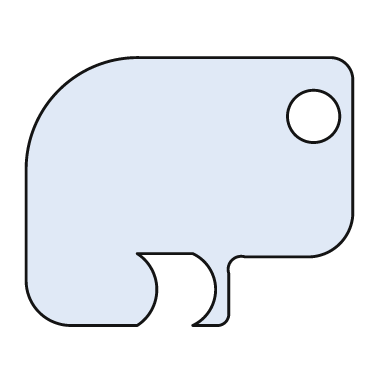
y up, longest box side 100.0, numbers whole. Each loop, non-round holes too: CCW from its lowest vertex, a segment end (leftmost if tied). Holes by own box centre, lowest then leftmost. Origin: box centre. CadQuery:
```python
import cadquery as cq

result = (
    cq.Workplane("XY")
    .moveTo(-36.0, -41.0)
    .lineTo(-16.0, -41.0)
    .threePointArc((-10.0, -30.0), (-16.0, -19.0))
    .lineTo(1.0, -19.0)
    .threePointArc((8.0, -30.0), (1.0, -41.0))
    .lineTo(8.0, -41.0)
    .threePointArc((11.0, -40.0), (12.0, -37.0))
    .lineTo(12.0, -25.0)
    .threePointArc((13.0, -21.0), (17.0, -20.0))
    .lineTo(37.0, -20.0)
    .threePointArc((46.0, -16.0), (50.0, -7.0))
    .lineTo(50.0, 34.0)
    .threePointArc((48.0, 39.0), (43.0, 41.0))
    .lineTo(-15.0, 41.0)
    .threePointArc((-40.0, 31.0), (-50.0, 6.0))
    .lineTo(-50.0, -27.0)
    .threePointArc((-46.0, -37.0), (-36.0, -41.0))
    .close()
    .moveTo(38.0, 23.0)
    .circle(8.0)
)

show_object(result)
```